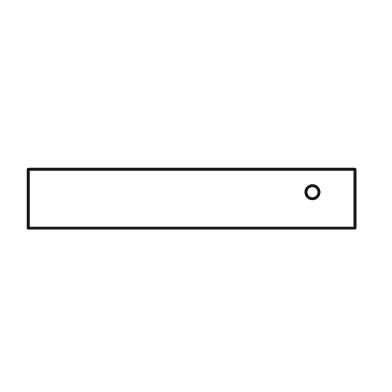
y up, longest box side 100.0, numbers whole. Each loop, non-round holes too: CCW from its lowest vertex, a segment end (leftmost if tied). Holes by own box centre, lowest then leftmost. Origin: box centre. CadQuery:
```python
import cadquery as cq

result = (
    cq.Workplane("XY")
    .moveTo(-50.0, -9.0)
    .lineTo(50.0, -9.0)
    .lineTo(50.0, 9.0)
    .lineTo(-50.0, 9.0)
    .close()
    .moveTo(37.0, 2.0)
    .circle(2.0)
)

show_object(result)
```